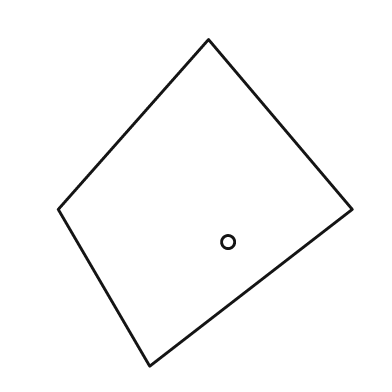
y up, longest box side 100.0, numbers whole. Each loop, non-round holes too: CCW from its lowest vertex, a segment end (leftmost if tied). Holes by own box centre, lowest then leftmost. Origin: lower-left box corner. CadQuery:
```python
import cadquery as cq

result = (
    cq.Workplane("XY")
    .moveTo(28.0, 0.0)
    .lineTo(90.0, 48.0)
    .lineTo(46.0, 100.0)
    .lineTo(0.0, 48.0)
    .close()
    .moveTo(52.0, 38.0)
    .circle(2.0)
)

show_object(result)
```